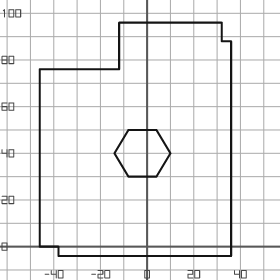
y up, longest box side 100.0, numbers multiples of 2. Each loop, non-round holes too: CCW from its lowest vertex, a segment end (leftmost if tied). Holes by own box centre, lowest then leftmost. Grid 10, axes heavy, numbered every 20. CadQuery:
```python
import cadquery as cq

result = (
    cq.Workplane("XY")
    .moveTo(-38.0, -4.0)
    .lineTo(36.0, -4.0)
    .lineTo(36.0, 88.0)
    .lineTo(32.0, 88.0)
    .lineTo(32.0, 96.0)
    .lineTo(-12.0, 96.0)
    .lineTo(-12.0, 76.0)
    .lineTo(-46.0, 76.0)
    .lineTo(-46.0, 0.0)
    .lineTo(-38.0, 0.0)
    .close()
    .moveTo(-8.0, 30.0)
    .lineTo(4.0, 30.0)
    .lineTo(10.0, 40.0)
    .lineTo(4.0, 50.0)
    .lineTo(-8.0, 50.0)
    .lineTo(-14.0, 40.0)
    .close()
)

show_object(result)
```